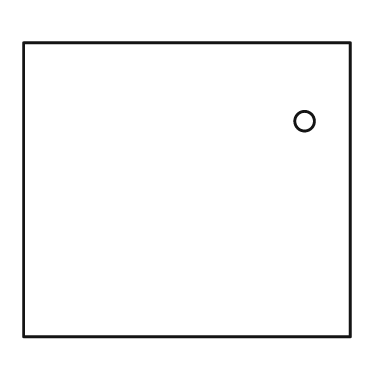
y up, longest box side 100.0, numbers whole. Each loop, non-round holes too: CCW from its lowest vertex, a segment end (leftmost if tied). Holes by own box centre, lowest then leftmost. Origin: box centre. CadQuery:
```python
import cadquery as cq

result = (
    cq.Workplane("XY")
    .moveTo(-50.0, -45.0)
    .lineTo(50.0, -45.0)
    .lineTo(50.0, 45.0)
    .lineTo(-50.0, 45.0)
    .close()
    .moveTo(36.0, 21.0)
    .circle(3.0)
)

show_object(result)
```